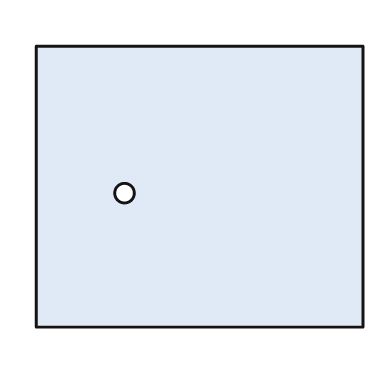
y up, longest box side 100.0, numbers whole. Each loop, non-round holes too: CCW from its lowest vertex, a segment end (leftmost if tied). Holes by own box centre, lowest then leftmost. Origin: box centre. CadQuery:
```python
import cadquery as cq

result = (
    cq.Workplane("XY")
    .moveTo(-50.0, -43.0)
    .lineTo(50.0, -43.0)
    .lineTo(50.0, 43.0)
    .lineTo(-50.0, 43.0)
    .close()
    .moveTo(-23.0, -2.0)
    .circle(3.0)
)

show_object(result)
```